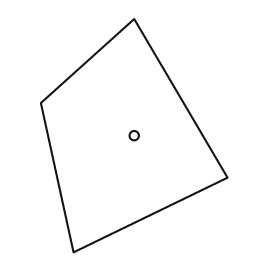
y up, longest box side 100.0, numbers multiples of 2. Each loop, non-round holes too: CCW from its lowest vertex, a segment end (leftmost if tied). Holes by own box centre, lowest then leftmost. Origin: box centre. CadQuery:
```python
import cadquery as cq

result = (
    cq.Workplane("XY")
    .moveTo(-26.0, -50.0)
    .lineTo(40.0, -18.0)
    .lineTo(0.0, 50.0)
    .lineTo(-40.0, 14.0)
    .close()
    .moveTo(0.0, 0.0)
    .circle(2.0)
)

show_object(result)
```